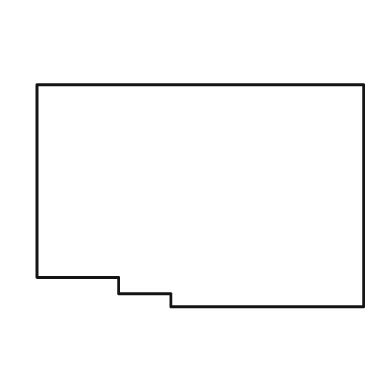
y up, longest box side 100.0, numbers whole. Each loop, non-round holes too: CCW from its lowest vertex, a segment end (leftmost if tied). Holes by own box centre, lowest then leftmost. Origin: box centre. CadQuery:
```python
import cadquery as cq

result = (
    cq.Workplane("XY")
    .moveTo(-9.0, -34.0)
    .lineTo(50.0, -34.0)
    .lineTo(50.0, 34.0)
    .lineTo(-50.0, 34.0)
    .lineTo(-50.0, -25.0)
    .lineTo(-25.0, -25.0)
    .lineTo(-25.0, -30.0)
    .lineTo(-9.0, -30.0)
    .close()
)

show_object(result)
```